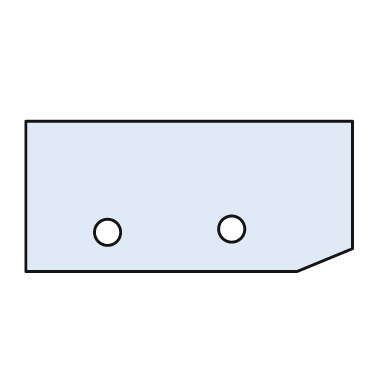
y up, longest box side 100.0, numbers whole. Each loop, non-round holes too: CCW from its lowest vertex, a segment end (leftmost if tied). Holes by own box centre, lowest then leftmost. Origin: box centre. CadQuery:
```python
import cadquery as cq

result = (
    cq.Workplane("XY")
    .moveTo(-50.0, -23.0)
    .lineTo(33.0, -23.0)
    .lineTo(50.0, -16.0)
    .lineTo(50.0, 23.0)
    .lineTo(-50.0, 23.0)
    .close()
    .moveTo(-25.0, -11.0)
    .circle(4.0)
    .moveTo(13.0, -10.0)
    .circle(4.0)
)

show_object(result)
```